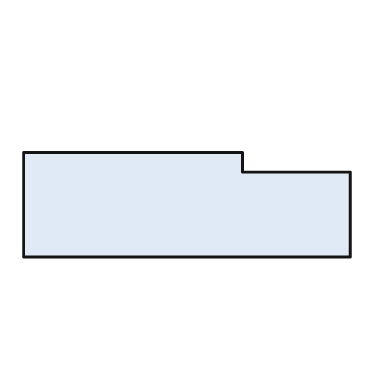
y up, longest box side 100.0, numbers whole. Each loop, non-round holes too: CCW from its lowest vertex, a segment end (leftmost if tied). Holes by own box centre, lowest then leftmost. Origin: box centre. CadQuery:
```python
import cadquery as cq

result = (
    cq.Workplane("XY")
    .moveTo(-50.0, -16.0)
    .lineTo(50.0, -16.0)
    .lineTo(50.0, 10.0)
    .lineTo(17.0, 10.0)
    .lineTo(17.0, 16.0)
    .lineTo(-50.0, 16.0)
    .close()
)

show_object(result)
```